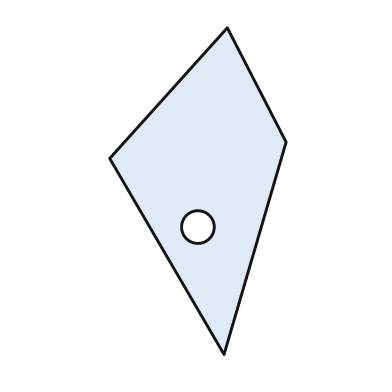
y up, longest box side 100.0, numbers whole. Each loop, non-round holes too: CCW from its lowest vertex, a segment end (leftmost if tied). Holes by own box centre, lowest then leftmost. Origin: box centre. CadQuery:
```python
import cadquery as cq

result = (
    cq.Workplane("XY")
    .moveTo(8.0, -50.0)
    .lineTo(27.0, 15.0)
    .lineTo(9.0, 50.0)
    .lineTo(-27.0, 10.0)
    .close()
    .moveTo(0.0, -11.0)
    .circle(5.0)
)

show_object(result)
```